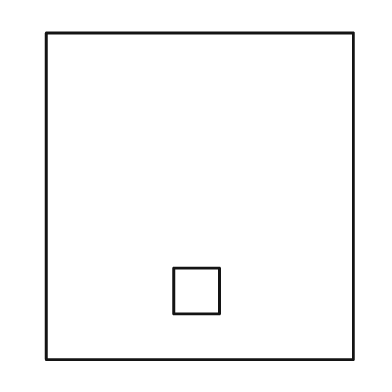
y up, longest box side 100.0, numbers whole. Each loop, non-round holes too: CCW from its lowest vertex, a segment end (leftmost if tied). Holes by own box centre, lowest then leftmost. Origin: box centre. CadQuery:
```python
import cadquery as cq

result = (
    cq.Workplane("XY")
    .moveTo(-47.0, -50.0)
    .lineTo(47.0, -50.0)
    .lineTo(47.0, 50.0)
    .lineTo(-47.0, 50.0)
    .close()
    .moveTo(-8.0, -36.0)
    .lineTo(6.0, -36.0)
    .lineTo(6.0, -22.0)
    .lineTo(-8.0, -22.0)
    .close()
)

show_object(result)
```